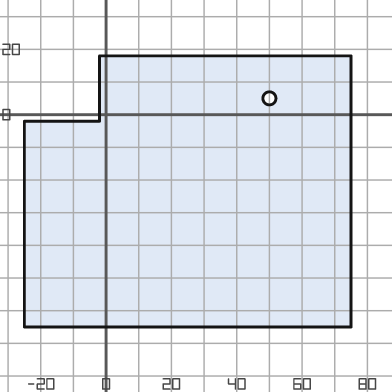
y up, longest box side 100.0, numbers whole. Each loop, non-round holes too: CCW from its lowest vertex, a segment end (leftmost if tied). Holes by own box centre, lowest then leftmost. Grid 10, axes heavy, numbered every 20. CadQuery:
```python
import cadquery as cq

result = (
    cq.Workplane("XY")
    .moveTo(-25.0, -65.0)
    .lineTo(75.0, -65.0)
    .lineTo(75.0, 18.0)
    .lineTo(-2.0, 18.0)
    .lineTo(-2.0, -2.0)
    .lineTo(-25.0, -2.0)
    .close()
    .moveTo(50.0, 5.0)
    .circle(2.0)
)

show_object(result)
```